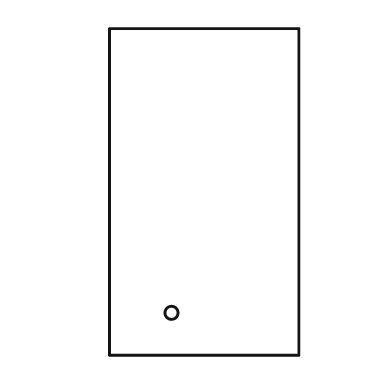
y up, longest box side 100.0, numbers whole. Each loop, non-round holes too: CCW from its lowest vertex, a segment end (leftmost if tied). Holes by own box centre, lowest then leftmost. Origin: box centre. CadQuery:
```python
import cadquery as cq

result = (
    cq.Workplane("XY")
    .moveTo(-29.0, -50.0)
    .lineTo(29.0, -50.0)
    .lineTo(29.0, 50.0)
    .lineTo(-29.0, 50.0)
    .close()
    .moveTo(-10.0, -37.0)
    .circle(2.0)
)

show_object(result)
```